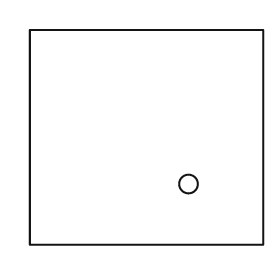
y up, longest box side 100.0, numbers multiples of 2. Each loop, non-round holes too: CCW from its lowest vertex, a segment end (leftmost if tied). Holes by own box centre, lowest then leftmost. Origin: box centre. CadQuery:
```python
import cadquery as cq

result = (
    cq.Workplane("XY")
    .moveTo(-50.0, -46.0)
    .lineTo(50.0, -46.0)
    .lineTo(50.0, 46.0)
    .lineTo(-50.0, 46.0)
    .close()
    .moveTo(18.0, -20.0)
    .circle(4.0)
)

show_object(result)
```